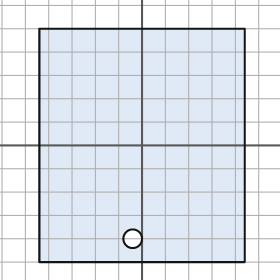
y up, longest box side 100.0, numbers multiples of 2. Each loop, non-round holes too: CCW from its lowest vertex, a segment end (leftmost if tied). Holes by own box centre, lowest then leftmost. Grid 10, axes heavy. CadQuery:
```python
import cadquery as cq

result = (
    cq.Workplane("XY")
    .moveTo(-44.0, -50.0)
    .lineTo(44.0, -50.0)
    .lineTo(44.0, 50.0)
    .lineTo(-44.0, 50.0)
    .close()
    .moveTo(-4.0, -40.0)
    .circle(4.0)
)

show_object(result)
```